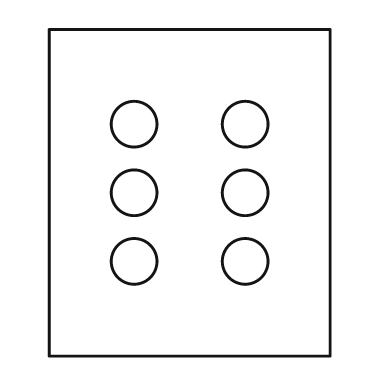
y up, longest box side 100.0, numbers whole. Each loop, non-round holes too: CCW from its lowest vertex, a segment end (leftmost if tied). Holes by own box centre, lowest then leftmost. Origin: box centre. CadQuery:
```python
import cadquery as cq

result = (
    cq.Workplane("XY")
    .moveTo(-43.0, -50.0)
    .lineTo(43.0, -50.0)
    .lineTo(43.0, 50.0)
    .lineTo(-43.0, 50.0)
    .close()
    .moveTo(-17.0, -21.0)
    .circle(7.0)
    .moveTo(17.0, -21.0)
    .circle(7.0)
    .moveTo(-17.0, 0.0)
    .circle(7.0)
    .moveTo(17.0, 0.0)
    .circle(7.0)
    .moveTo(-17.0, 21.0)
    .circle(7.0)
    .moveTo(17.0, 21.0)
    .circle(7.0)
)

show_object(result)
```